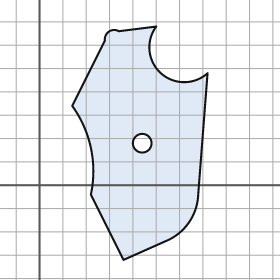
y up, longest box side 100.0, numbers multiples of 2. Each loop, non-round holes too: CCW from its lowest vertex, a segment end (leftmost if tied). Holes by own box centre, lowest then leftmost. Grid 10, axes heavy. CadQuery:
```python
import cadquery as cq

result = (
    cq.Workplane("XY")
    .moveTo(36.0, -32.0)
    .lineTo(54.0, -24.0)
    .threePointArc((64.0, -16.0), (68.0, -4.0))
    .lineTo(72.0, 48.0)
    .threePointArc((52.0, 48.0), (50.0, 68.0))
    .lineTo(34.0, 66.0)
    .threePointArc((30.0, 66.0), (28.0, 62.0))
    .lineTo(14.0, 34.0)
    .threePointArc((22.0, 16.0), (22.0, -4.0))
    .close()
    .moveTo(44.0, 18.0)
    .circle(4.0)
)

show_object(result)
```